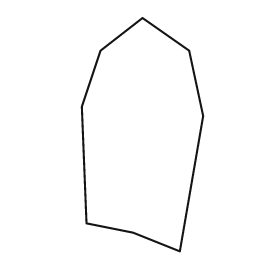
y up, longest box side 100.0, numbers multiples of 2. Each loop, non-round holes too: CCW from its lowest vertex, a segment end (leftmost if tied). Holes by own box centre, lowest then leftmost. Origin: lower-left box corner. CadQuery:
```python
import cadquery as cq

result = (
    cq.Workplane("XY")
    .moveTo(42.0, 0.0)
    .lineTo(52.0, 58.0)
    .lineTo(46.0, 86.0)
    .lineTo(26.0, 100.0)
    .lineTo(8.0, 86.0)
    .lineTo(0.0, 62.0)
    .lineTo(2.0, 12.0)
    .lineTo(22.0, 8.0)
    .close()
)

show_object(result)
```